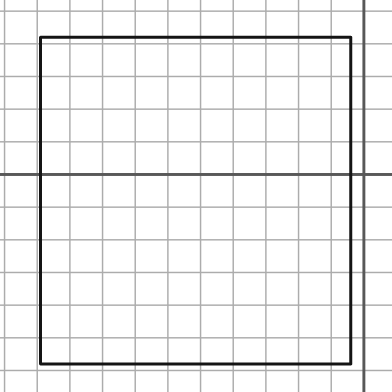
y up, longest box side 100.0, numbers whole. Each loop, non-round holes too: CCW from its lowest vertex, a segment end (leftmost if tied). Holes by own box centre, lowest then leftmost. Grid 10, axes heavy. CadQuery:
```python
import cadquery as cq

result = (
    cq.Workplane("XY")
    .moveTo(-99.0, -58.0)
    .lineTo(-4.0, -58.0)
    .lineTo(-4.0, 42.0)
    .lineTo(-99.0, 42.0)
    .close()
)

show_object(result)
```